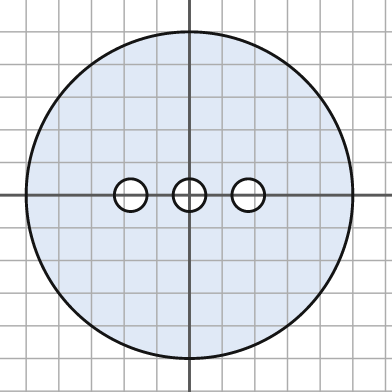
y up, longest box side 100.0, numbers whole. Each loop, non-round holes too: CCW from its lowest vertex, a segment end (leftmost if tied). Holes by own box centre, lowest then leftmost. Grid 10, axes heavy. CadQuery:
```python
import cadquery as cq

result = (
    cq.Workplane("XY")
    .moveTo(0.0, 0.0)
    .circle(50.0)
    .moveTo(-18.0, 0.0)
    .circle(5.0)
    .moveTo(0.0, 0.0)
    .circle(5.0)
    .moveTo(18.0, 0.0)
    .circle(5.0)
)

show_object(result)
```